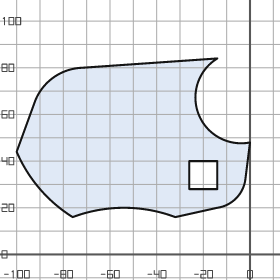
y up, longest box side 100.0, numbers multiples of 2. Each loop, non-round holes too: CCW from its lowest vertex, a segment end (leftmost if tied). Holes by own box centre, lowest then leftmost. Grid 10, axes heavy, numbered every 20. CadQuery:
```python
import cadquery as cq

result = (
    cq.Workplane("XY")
    .moveTo(-76.0, 16.0)
    .threePointArc((-54.0, 20.0), (-32.0, 16.0))
    .lineTo(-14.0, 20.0)
    .threePointArc((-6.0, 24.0), (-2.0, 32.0))
    .lineTo(0.0, 48.0)
    .threePointArc((-22.0, 60.0), (-14.0, 84.0))
    .lineTo(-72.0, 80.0)
    .threePointArc((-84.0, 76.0), (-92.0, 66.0))
    .lineTo(-100.0, 44.0)
    .threePointArc((-90.0, 28.0), (-76.0, 16.0))
    .close()
    .moveTo(-26.0, 28.0)
    .lineTo(-14.0, 28.0)
    .lineTo(-14.0, 40.0)
    .lineTo(-26.0, 40.0)
    .close()
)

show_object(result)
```